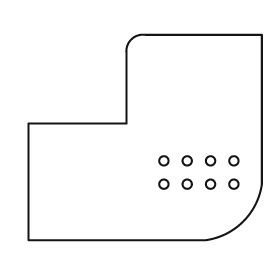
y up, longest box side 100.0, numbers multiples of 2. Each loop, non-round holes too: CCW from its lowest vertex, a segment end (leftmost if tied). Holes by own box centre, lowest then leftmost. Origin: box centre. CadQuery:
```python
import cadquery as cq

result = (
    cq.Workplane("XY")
    .moveTo(-50.0, -44.0)
    .lineTo(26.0, -44.0)
    .threePointArc((42.0, -36.0), (50.0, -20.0))
    .lineTo(50.0, 44.0)
    .lineTo(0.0, 44.0)
    .threePointArc((-6.0, 42.0), (-8.0, 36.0))
    .lineTo(-8.0, 6.0)
    .lineTo(-50.0, 6.0)
    .close()
    .moveTo(8.0, -20.0)
    .circle(2.0)
    .moveTo(18.0, -20.0)
    .circle(2.0)
    .moveTo(28.0, -20.0)
    .circle(2.0)
    .moveTo(38.0, -20.0)
    .circle(2.0)
    .moveTo(8.0, -10.0)
    .circle(2.0)
    .moveTo(18.0, -10.0)
    .circle(2.0)
    .moveTo(28.0, -10.0)
    .circle(2.0)
    .moveTo(38.0, -10.0)
    .circle(2.0)
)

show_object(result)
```